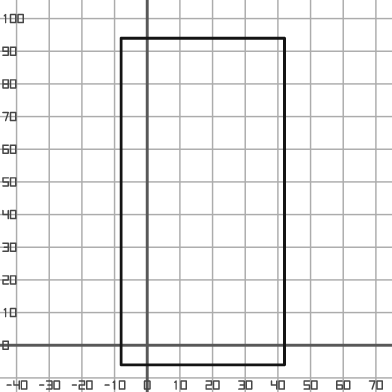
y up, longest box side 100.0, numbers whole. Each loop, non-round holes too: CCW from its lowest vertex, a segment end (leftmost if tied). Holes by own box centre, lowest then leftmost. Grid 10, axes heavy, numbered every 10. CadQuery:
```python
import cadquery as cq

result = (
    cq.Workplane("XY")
    .moveTo(-8.0, -6.0)
    .lineTo(42.0, -6.0)
    .lineTo(42.0, 94.0)
    .lineTo(-8.0, 94.0)
    .close()
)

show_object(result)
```